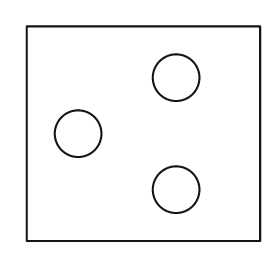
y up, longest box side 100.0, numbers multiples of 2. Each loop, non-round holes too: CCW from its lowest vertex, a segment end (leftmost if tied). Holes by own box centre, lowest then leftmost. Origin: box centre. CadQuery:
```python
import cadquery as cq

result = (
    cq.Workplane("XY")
    .moveTo(-50.0, -46.0)
    .lineTo(50.0, -46.0)
    .lineTo(50.0, 46.0)
    .lineTo(-50.0, 46.0)
    .close()
    .moveTo(14.0, -24.0)
    .circle(10.0)
    .moveTo(-28.0, 0.0)
    .circle(10.0)
    .moveTo(14.0, 24.0)
    .circle(10.0)
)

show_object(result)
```